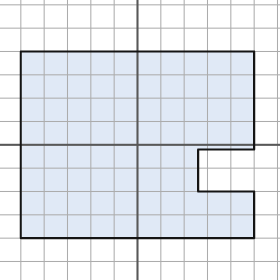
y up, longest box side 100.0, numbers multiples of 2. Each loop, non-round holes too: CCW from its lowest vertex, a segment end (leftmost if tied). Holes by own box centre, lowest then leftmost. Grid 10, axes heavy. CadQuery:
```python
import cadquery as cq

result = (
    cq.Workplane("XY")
    .moveTo(-50.0, -40.0)
    .lineTo(50.0, -40.0)
    .lineTo(50.0, -20.0)
    .lineTo(26.0, -20.0)
    .lineTo(26.0, -2.0)
    .lineTo(50.0, -2.0)
    .lineTo(50.0, 40.0)
    .lineTo(-50.0, 40.0)
    .close()
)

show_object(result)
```